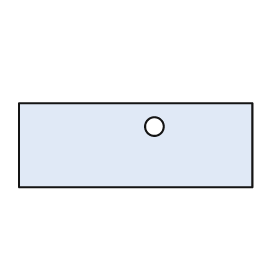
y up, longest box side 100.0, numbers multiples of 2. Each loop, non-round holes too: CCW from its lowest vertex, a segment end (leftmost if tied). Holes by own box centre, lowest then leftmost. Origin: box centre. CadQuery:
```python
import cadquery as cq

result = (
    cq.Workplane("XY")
    .moveTo(-50.0, -18.0)
    .lineTo(50.0, -18.0)
    .lineTo(50.0, 18.0)
    .lineTo(-50.0, 18.0)
    .close()
    .moveTo(8.0, 8.0)
    .circle(4.0)
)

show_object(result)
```